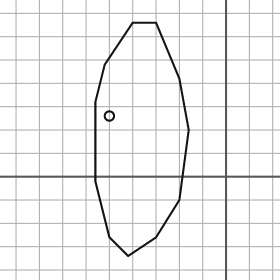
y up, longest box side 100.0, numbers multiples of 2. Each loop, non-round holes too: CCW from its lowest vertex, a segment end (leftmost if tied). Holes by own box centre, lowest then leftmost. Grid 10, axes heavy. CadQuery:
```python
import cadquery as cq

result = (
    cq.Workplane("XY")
    .moveTo(-42.0, -34.0)
    .lineTo(-30.0, -26.0)
    .lineTo(-20.0, -10.0)
    .lineTo(-16.0, 20.0)
    .lineTo(-20.0, 42.0)
    .lineTo(-30.0, 66.0)
    .lineTo(-40.0, 66.0)
    .lineTo(-52.0, 48.0)
    .lineTo(-56.0, 32.0)
    .lineTo(-56.0, -2.0)
    .lineTo(-50.0, -26.0)
    .close()
    .moveTo(-50.0, 26.0)
    .circle(2.0)
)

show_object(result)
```